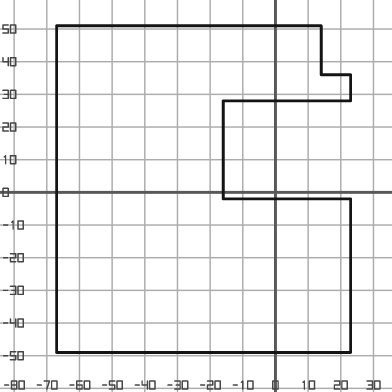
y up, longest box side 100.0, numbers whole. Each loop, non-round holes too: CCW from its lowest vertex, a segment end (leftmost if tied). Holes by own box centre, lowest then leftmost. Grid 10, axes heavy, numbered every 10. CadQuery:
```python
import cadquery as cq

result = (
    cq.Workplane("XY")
    .moveTo(-67.0, -49.0)
    .lineTo(23.0, -49.0)
    .lineTo(23.0, -2.0)
    .lineTo(-16.0, -2.0)
    .lineTo(-16.0, 28.0)
    .lineTo(23.0, 28.0)
    .lineTo(23.0, 36.0)
    .lineTo(14.0, 36.0)
    .lineTo(14.0, 51.0)
    .lineTo(-67.0, 51.0)
    .close()
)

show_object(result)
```